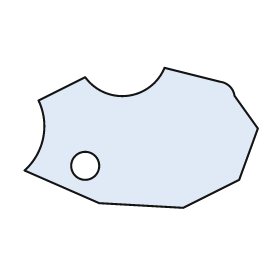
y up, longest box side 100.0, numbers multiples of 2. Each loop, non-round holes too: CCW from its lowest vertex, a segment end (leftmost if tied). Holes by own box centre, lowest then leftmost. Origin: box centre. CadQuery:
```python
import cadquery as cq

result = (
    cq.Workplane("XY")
    .moveTo(18.0, -30.0)
    .lineTo(42.0, -18.0)
    .lineTo(50.0, 4.0)
    .lineTo(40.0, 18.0)
    .threePointArc((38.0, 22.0), (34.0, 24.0))
    .lineTo(10.0, 30.0)
    .threePointArc((-6.0, 18.0), (-24.0, 26.0))
    .lineTo(-44.0, 16.0)
    .threePointArc((-42.0, 0.0), (-50.0, -14.0))
    .lineTo(-18.0, -28.0)
    .close()
    .moveTo(-24.0, -12.0)
    .circle(6.0)
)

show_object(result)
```